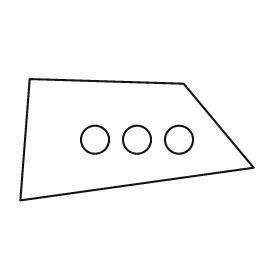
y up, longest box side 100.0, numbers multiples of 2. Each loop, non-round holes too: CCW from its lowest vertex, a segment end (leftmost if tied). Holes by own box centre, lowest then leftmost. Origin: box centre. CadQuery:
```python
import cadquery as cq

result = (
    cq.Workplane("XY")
    .moveTo(-50.0, -26.0)
    .lineTo(50.0, -12.0)
    .lineTo(20.0, 24.0)
    .lineTo(-46.0, 26.0)
    .close()
    .moveTo(-18.0, 0.0)
    .circle(6.0)
    .moveTo(0.0, 0.0)
    .circle(6.0)
    .moveTo(18.0, 0.0)
    .circle(6.0)
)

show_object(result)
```